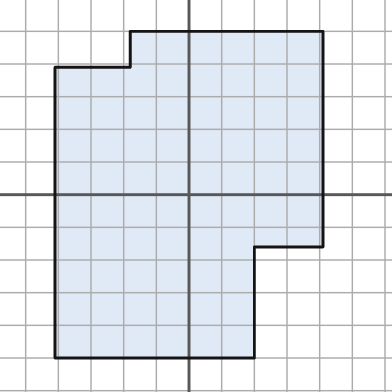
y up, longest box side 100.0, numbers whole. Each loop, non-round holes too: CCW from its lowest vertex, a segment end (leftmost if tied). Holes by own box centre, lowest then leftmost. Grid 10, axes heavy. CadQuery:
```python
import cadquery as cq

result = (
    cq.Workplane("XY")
    .moveTo(-41.0, -50.0)
    .lineTo(20.0, -50.0)
    .lineTo(20.0, -16.0)
    .lineTo(41.0, -16.0)
    .lineTo(41.0, 50.0)
    .lineTo(-18.0, 50.0)
    .lineTo(-18.0, 39.0)
    .lineTo(-41.0, 39.0)
    .close()
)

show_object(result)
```